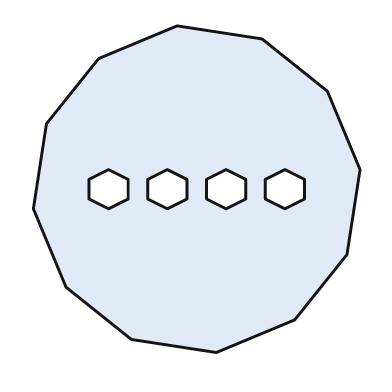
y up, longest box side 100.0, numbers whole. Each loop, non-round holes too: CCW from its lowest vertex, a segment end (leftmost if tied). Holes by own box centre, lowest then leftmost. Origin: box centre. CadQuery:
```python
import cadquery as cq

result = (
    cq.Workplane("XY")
    .moveTo(6.0, -50.0)
    .lineTo(30.0, -40.0)
    .lineTo(46.0, -20.0)
    .lineTo(50.0, 6.0)
    .lineTo(40.0, 30.0)
    .lineTo(20.0, 46.0)
    .lineTo(-6.0, 50.0)
    .lineTo(-30.0, 40.0)
    .lineTo(-46.0, 20.0)
    .lineTo(-50.0, -6.0)
    .lineTo(-40.0, -30.0)
    .lineTo(-20.0, -46.0)
    .close()
    .moveTo(-27.0, -6.0)
    .lineTo(-21.0, -3.0)
    .lineTo(-21.0, 3.0)
    .lineTo(-27.0, 6.0)
    .lineTo(-33.0, 3.0)
    .lineTo(-33.0, -3.0)
    .close()
    .moveTo(-9.0, -6.0)
    .lineTo(-3.0, -3.0)
    .lineTo(-3.0, 3.0)
    .lineTo(-9.0, 6.0)
    .lineTo(-15.0, 3.0)
    .lineTo(-15.0, -3.0)
    .close()
    .moveTo(9.0, -6.0)
    .lineTo(15.0, -3.0)
    .lineTo(15.0, 3.0)
    .lineTo(9.0, 6.0)
    .lineTo(3.0, 3.0)
    .lineTo(3.0, -3.0)
    .close()
    .moveTo(27.0, -6.0)
    .lineTo(33.0, -3.0)
    .lineTo(33.0, 3.0)
    .lineTo(27.0, 6.0)
    .lineTo(21.0, 3.0)
    .lineTo(21.0, -3.0)
    .close()
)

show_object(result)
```